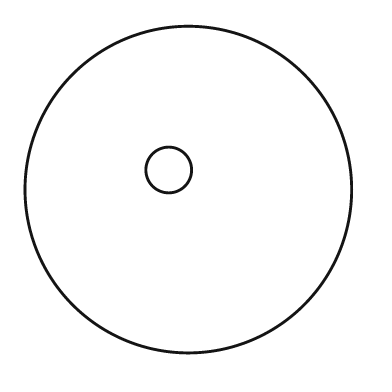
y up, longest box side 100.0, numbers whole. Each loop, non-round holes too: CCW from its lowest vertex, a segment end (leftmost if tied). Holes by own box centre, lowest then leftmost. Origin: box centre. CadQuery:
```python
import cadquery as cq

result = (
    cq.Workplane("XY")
    .moveTo(0.0, 0.0)
    .circle(50.0)
    .moveTo(-6.0, 6.0)
    .circle(7.0)
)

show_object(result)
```